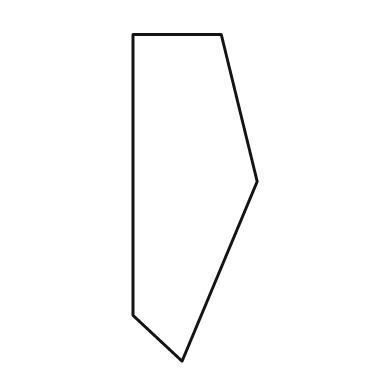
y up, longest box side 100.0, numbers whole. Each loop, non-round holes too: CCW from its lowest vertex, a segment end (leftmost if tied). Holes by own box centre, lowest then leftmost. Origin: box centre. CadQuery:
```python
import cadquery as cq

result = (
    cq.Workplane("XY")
    .moveTo(-4.0, -50.0)
    .lineTo(19.0, 5.0)
    .lineTo(8.0, 50.0)
    .lineTo(-19.0, 50.0)
    .lineTo(-19.0, -36.0)
    .close()
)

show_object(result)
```